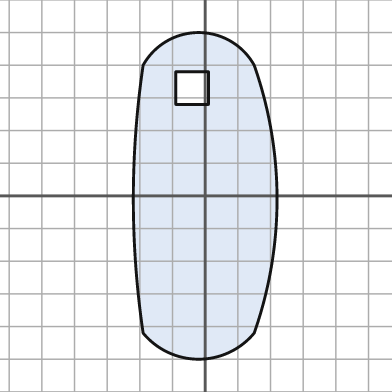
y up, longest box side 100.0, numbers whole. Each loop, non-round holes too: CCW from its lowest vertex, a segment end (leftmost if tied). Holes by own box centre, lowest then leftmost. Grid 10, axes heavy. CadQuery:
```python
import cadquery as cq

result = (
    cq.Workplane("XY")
    .moveTo(-19.0, -42.0)
    .threePointArc((-2.0, -50.0), (15.0, -42.0))
    .threePointArc((22.0, -1.0), (15.0, 40.0))
    .threePointArc((-2.0, 50.0), (-19.0, 40.0))
    .threePointArc((-22.0, -1.0), (-19.0, -42.0))
    .close()
    .moveTo(-9.0, 28.0)
    .lineTo(1.0, 28.0)
    .lineTo(1.0, 38.0)
    .lineTo(-9.0, 38.0)
    .close()
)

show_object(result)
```